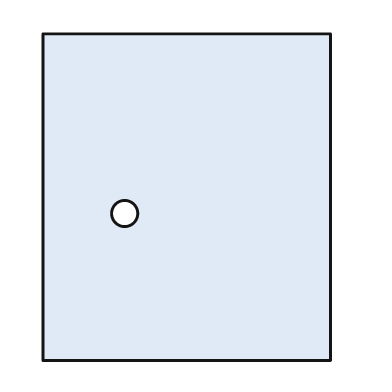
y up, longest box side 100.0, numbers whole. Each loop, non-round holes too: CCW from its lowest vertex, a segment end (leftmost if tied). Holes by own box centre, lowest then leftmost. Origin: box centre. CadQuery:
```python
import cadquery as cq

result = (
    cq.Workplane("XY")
    .moveTo(-44.0, -50.0)
    .lineTo(44.0, -50.0)
    .lineTo(44.0, 50.0)
    .lineTo(-44.0, 50.0)
    .close()
    .moveTo(-19.0, -5.0)
    .circle(4.0)
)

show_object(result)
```